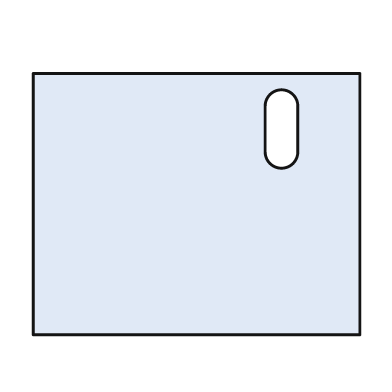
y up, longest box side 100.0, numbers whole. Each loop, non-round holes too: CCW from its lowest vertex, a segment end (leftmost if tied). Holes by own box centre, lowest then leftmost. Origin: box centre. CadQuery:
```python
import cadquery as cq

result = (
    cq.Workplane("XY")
    .moveTo(-50.0, -40.0)
    .lineTo(50.0, -40.0)
    .lineTo(50.0, 40.0)
    .lineTo(-50.0, 40.0)
    .close()
    .moveTo(21.0, 16.0)
    .threePointArc((26.0, 11.0), (31.0, 16.0))
    .lineTo(31.0, 30.0)
    .threePointArc((26.0, 35.0), (21.0, 30.0))
    .close()
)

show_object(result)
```